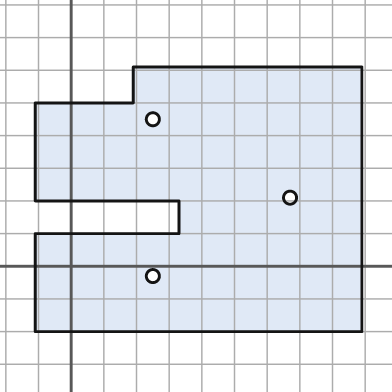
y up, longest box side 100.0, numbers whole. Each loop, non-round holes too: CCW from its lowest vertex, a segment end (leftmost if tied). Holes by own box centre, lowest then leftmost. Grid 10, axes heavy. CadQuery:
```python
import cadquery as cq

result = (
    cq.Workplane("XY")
    .moveTo(-11.0, -20.0)
    .lineTo(89.0, -20.0)
    .lineTo(89.0, 61.0)
    .lineTo(19.0, 61.0)
    .lineTo(19.0, 50.0)
    .lineTo(-11.0, 50.0)
    .lineTo(-11.0, 20.0)
    .lineTo(33.0, 20.0)
    .lineTo(33.0, 10.0)
    .lineTo(-11.0, 10.0)
    .close()
    .moveTo(25.0, -3.0)
    .circle(2.0)
    .moveTo(67.0, 21.0)
    .circle(2.0)
    .moveTo(25.0, 45.0)
    .circle(2.0)
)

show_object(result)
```